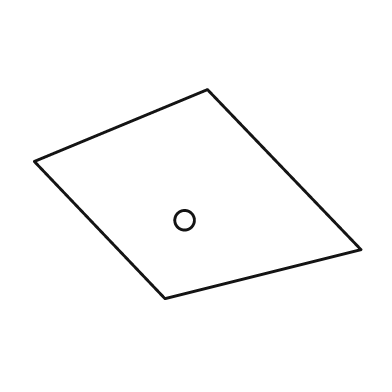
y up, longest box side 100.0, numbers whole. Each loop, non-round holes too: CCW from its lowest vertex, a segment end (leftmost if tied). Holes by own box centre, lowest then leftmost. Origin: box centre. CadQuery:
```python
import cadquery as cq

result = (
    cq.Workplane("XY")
    .moveTo(-10.0, -32.0)
    .lineTo(50.0, -17.0)
    .lineTo(3.0, 32.0)
    .lineTo(-50.0, 10.0)
    .close()
    .moveTo(-4.0, -8.0)
    .circle(3.0)
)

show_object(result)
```